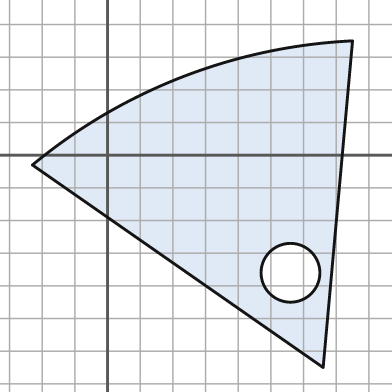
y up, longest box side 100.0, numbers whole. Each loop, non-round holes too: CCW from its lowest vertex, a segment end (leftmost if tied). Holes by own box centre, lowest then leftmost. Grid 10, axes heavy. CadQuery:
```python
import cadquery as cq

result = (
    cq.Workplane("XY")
    .moveTo(66.0, -65.0)
    .lineTo(75.0, 35.0)
    .threePointArc((23.0, 24.0), (-23.0, -3.0))
    .close()
    .moveTo(56.0, -36.0)
    .circle(9.0)
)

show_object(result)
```